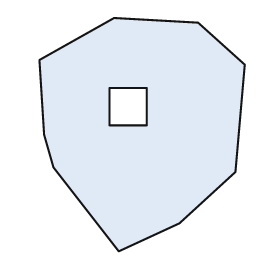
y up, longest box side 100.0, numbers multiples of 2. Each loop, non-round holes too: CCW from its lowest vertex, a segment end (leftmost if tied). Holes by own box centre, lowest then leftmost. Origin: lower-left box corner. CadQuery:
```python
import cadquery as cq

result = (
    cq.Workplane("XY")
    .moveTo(34.0, 0.0)
    .lineTo(60.0, 12.0)
    .lineTo(84.0, 34.0)
    .lineTo(88.0, 80.0)
    .lineTo(68.0, 98.0)
    .lineTo(32.0, 100.0)
    .lineTo(0.0, 82.0)
    .lineTo(2.0, 50.0)
    .lineTo(6.0, 36.0)
    .close()
    .moveTo(30.0, 54.0)
    .lineTo(46.0, 54.0)
    .lineTo(46.0, 70.0)
    .lineTo(30.0, 70.0)
    .close()
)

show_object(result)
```